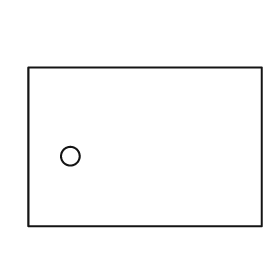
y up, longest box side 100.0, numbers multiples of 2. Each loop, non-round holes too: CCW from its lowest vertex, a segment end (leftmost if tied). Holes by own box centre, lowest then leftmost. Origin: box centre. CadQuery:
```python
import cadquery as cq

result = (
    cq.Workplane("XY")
    .moveTo(-50.0, -34.0)
    .lineTo(50.0, -34.0)
    .lineTo(50.0, 34.0)
    .lineTo(-50.0, 34.0)
    .close()
    .moveTo(-32.0, -4.0)
    .circle(4.0)
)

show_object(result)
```